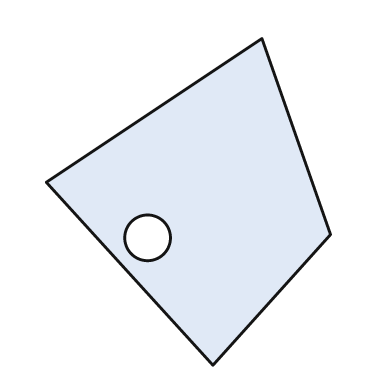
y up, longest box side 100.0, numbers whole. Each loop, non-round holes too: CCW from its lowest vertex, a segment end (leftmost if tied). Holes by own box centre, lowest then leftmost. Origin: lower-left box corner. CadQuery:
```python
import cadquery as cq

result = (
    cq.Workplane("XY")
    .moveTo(51.0, 0.0)
    .lineTo(87.0, 40.0)
    .lineTo(66.0, 100.0)
    .lineTo(0.0, 56.0)
    .close()
    .moveTo(31.0, 39.0)
    .circle(7.0)
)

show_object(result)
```